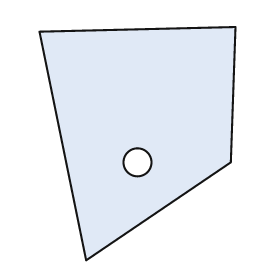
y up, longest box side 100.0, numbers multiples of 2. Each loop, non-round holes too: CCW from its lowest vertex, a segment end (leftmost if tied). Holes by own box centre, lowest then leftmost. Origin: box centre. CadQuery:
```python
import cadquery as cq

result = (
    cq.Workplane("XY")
    .moveTo(-22.0, -50.0)
    .lineTo(40.0, -8.0)
    .lineTo(42.0, 50.0)
    .lineTo(-42.0, 48.0)
    .close()
    .moveTo(0.0, -8.0)
    .circle(6.0)
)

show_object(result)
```